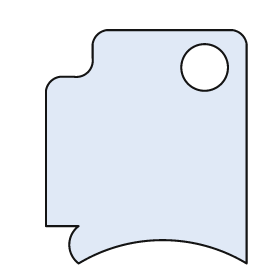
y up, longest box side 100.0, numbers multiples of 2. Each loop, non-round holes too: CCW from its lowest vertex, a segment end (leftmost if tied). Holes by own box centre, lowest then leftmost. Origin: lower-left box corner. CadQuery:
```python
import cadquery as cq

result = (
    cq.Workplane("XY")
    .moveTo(14.0, 0.0)
    .threePointArc((50.0, 10.0), (86.0, 0.0))
    .lineTo(86.0, 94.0)
    .threePointArc((84.0, 98.0), (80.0, 100.0))
    .lineTo(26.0, 100.0)
    .threePointArc((22.0, 98.0), (20.0, 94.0))
    .lineTo(20.0, 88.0)
    .threePointArc((18.0, 82.0), (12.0, 80.0))
    .lineTo(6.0, 80.0)
    .threePointArc((2.0, 78.0), (0.0, 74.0))
    .lineTo(0.0, 16.0)
    .lineTo(14.0, 16.0)
    .threePointArc((10.0, 8.0), (14.0, 0.0))
    .close()
    .moveTo(68.0, 84.0)
    .circle(10.0)
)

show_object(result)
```